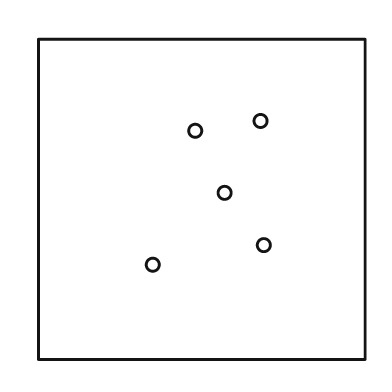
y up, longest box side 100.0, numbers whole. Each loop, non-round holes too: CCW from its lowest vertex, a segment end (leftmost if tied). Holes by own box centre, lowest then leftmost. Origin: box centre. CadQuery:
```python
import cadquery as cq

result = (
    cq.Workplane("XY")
    .moveTo(-50.0, -49.0)
    .lineTo(50.0, -49.0)
    .lineTo(50.0, 49.0)
    .lineTo(-50.0, 49.0)
    .close()
    .moveTo(-15.0, -20.0)
    .circle(2.0)
    .moveTo(19.0, -14.0)
    .circle(2.0)
    .moveTo(7.0, 2.0)
    .circle(2.0)
    .moveTo(-2.0, 21.0)
    .circle(2.0)
    .moveTo(18.0, 24.0)
    .circle(2.0)
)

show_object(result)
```